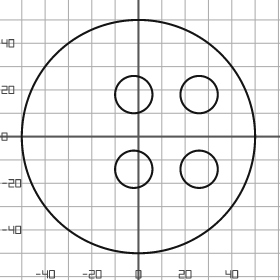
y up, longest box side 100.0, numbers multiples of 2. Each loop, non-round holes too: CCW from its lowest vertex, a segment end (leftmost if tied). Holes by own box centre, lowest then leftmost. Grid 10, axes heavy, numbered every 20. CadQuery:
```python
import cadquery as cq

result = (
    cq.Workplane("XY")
    .moveTo(0.0, 0.0)
    .circle(50.0)
    .moveTo(-2.0, -14.0)
    .circle(8.0)
    .moveTo(26.0, -14.0)
    .circle(8.0)
    .moveTo(-2.0, 18.0)
    .circle(8.0)
    .moveTo(26.0, 18.0)
    .circle(8.0)
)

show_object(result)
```